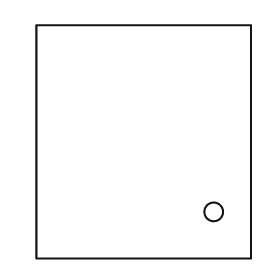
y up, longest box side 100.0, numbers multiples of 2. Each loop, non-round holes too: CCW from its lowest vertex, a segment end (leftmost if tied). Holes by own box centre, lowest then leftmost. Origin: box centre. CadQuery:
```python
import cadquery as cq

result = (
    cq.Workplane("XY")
    .moveTo(-46.0, -50.0)
    .lineTo(46.0, -50.0)
    .lineTo(46.0, 50.0)
    .lineTo(-46.0, 50.0)
    .close()
    .moveTo(30.0, -30.0)
    .circle(4.0)
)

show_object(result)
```